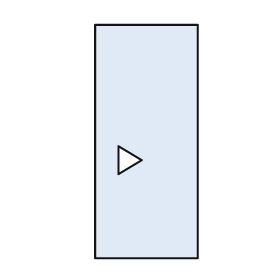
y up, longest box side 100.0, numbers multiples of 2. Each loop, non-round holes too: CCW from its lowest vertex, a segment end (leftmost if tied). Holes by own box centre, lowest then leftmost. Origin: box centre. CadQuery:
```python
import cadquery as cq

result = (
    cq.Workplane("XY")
    .moveTo(-22.0, -50.0)
    .lineTo(22.0, -50.0)
    .lineTo(22.0, 50.0)
    .lineTo(-22.0, 50.0)
    .close()
    .moveTo(-12.0, -14.0)
    .lineTo(-2.0, -8.0)
    .lineTo(-12.0, -2.0)
    .close()
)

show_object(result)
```